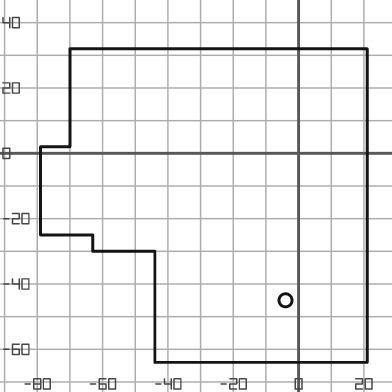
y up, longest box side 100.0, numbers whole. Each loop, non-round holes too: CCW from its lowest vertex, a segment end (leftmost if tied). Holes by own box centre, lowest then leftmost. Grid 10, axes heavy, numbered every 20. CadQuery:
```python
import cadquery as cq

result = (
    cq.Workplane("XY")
    .moveTo(-44.0, -64.0)
    .lineTo(21.0, -64.0)
    .lineTo(21.0, 32.0)
    .lineTo(-70.0, 32.0)
    .lineTo(-70.0, 2.0)
    .lineTo(-79.0, 2.0)
    .lineTo(-79.0, -25.0)
    .lineTo(-63.0, -25.0)
    .lineTo(-63.0, -30.0)
    .lineTo(-44.0, -30.0)
    .close()
    .moveTo(-4.0, -45.0)
    .circle(2.0)
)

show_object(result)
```